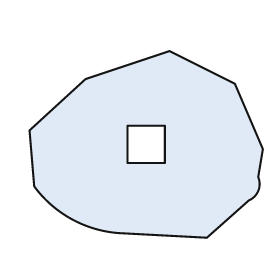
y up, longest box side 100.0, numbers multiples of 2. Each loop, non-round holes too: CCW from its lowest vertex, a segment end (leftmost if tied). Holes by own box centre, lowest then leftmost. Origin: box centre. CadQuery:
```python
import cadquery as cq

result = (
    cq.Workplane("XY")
    .moveTo(26.0, -40.0)
    .lineTo(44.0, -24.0)
    .threePointArc((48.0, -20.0), (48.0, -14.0))
    .lineTo(50.0, -2.0)
    .lineTo(38.0, 26.0)
    .lineTo(10.0, 40.0)
    .lineTo(-26.0, 28.0)
    .lineTo(-50.0, 6.0)
    .lineTo(-48.0, -18.0)
    .threePointArc((-32.0, -32.0), (-12.0, -38.0))
    .close()
    .moveTo(-8.0, -8.0)
    .lineTo(8.0, -8.0)
    .lineTo(8.0, 8.0)
    .lineTo(-8.0, 8.0)
    .close()
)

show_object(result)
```